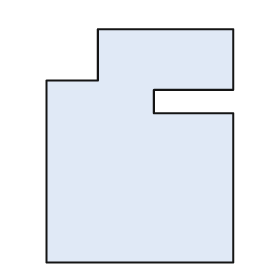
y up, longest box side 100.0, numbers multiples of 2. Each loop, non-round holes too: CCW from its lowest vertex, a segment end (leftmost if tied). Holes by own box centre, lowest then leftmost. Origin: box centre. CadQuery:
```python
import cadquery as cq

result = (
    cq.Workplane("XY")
    .moveTo(-40.0, -50.0)
    .lineTo(40.0, -50.0)
    .lineTo(40.0, 14.0)
    .lineTo(6.0, 14.0)
    .lineTo(6.0, 24.0)
    .lineTo(40.0, 24.0)
    .lineTo(40.0, 50.0)
    .lineTo(-18.0, 50.0)
    .lineTo(-18.0, 28.0)
    .lineTo(-40.0, 28.0)
    .close()
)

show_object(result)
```